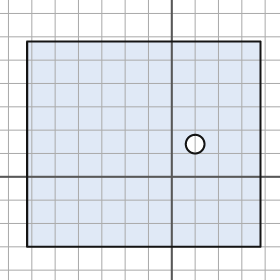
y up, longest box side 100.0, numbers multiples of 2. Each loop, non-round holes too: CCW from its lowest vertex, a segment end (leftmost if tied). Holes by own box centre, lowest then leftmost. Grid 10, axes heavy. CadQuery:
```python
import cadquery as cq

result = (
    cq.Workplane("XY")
    .moveTo(-62.0, -30.0)
    .lineTo(38.0, -30.0)
    .lineTo(38.0, 58.0)
    .lineTo(-62.0, 58.0)
    .close()
    .moveTo(10.0, 14.0)
    .circle(4.0)
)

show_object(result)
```